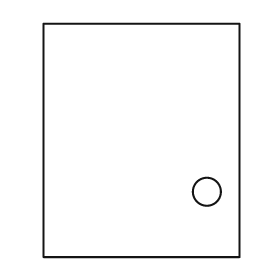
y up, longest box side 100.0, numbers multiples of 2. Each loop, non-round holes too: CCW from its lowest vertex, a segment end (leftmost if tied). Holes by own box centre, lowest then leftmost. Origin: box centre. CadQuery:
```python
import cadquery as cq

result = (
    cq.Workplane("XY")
    .moveTo(-42.0, -50.0)
    .lineTo(42.0, -50.0)
    .lineTo(42.0, 50.0)
    .lineTo(-42.0, 50.0)
    .close()
    .moveTo(28.0, -22.0)
    .circle(6.0)
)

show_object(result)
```